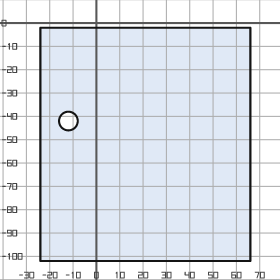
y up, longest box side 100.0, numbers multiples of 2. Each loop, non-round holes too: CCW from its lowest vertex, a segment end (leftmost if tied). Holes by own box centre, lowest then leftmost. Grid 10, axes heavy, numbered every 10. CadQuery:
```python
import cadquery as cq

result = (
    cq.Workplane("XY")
    .moveTo(-24.0, -102.0)
    .lineTo(66.0, -102.0)
    .lineTo(66.0, -2.0)
    .lineTo(-24.0, -2.0)
    .close()
    .moveTo(-12.0, -42.0)
    .circle(4.0)
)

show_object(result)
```